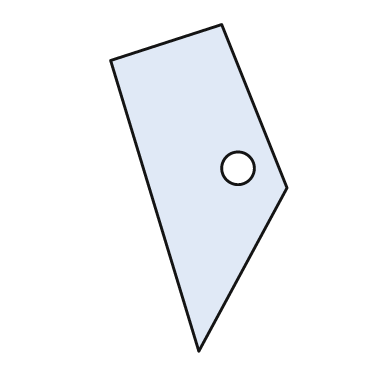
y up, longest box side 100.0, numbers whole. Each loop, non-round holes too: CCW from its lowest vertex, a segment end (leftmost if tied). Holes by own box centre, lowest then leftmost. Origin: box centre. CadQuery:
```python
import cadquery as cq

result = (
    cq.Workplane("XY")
    .moveTo(0.0, -50.0)
    .lineTo(27.0, 0.0)
    .lineTo(7.0, 50.0)
    .lineTo(-27.0, 39.0)
    .close()
    .moveTo(12.0, 6.0)
    .circle(5.0)
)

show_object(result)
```